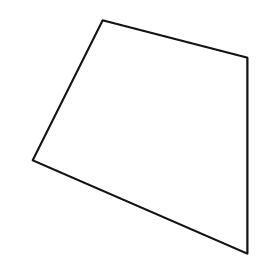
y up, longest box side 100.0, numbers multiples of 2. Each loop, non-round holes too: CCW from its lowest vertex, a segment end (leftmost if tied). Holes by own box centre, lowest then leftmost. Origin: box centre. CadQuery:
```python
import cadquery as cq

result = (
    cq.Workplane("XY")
    .moveTo(46.0, -50.0)
    .lineTo(46.0, 34.0)
    .lineTo(-16.0, 50.0)
    .lineTo(-46.0, -10.0)
    .close()
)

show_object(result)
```